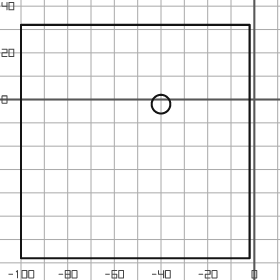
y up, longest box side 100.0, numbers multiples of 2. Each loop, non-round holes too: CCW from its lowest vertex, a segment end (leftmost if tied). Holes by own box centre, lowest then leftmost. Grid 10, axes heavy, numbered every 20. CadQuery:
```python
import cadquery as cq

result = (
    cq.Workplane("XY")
    .moveTo(-100.0, -68.0)
    .lineTo(-2.0, -68.0)
    .lineTo(-2.0, 32.0)
    .lineTo(-100.0, 32.0)
    .close()
    .moveTo(-40.0, -2.0)
    .circle(4.0)
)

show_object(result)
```